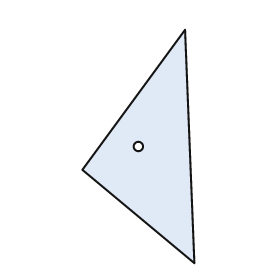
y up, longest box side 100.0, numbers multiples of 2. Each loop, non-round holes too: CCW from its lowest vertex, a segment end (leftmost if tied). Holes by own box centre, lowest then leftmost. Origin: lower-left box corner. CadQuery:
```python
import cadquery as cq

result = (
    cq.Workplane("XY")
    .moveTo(48.0, 0.0)
    .lineTo(44.0, 100.0)
    .lineTo(0.0, 40.0)
    .close()
    .moveTo(24.0, 50.0)
    .circle(2.0)
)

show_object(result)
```